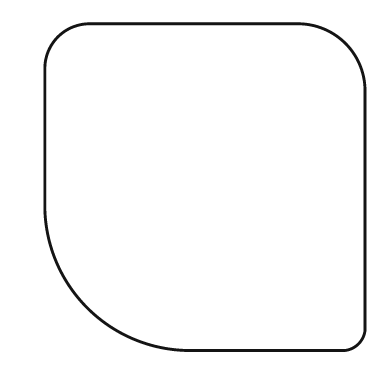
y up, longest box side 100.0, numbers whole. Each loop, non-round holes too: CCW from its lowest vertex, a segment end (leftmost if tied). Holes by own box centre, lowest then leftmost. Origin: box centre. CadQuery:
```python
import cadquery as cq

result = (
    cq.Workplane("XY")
    .moveTo(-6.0, -50.0)
    .lineTo(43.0, -50.0)
    .threePointArc((47.0, -48.0), (49.0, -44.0))
    .lineTo(49.0, 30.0)
    .threePointArc((43.0, 44.0), (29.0, 50.0))
    .lineTo(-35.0, 50.0)
    .threePointArc((-45.0, 46.0), (-49.0, 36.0))
    .lineTo(-49.0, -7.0)
    .threePointArc((-36.0, -37.0), (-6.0, -50.0))
    .close()
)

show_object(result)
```